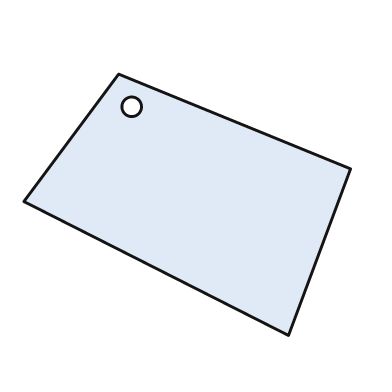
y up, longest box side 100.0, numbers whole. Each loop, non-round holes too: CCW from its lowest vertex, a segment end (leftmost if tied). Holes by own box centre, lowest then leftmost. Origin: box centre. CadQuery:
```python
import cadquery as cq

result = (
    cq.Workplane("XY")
    .moveTo(31.0, -40.0)
    .lineTo(50.0, 11.0)
    .lineTo(-21.0, 40.0)
    .lineTo(-50.0, 1.0)
    .close()
    .moveTo(-17.0, 30.0)
    .circle(3.0)
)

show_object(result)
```